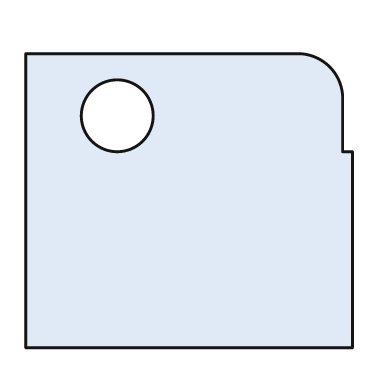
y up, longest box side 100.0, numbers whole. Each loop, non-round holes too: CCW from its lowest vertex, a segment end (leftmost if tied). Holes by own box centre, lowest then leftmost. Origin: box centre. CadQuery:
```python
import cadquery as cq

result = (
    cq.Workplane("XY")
    .moveTo(-50.0, -45.0)
    .lineTo(50.0, -45.0)
    .lineTo(50.0, 15.0)
    .lineTo(47.0, 15.0)
    .lineTo(47.0, 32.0)
    .threePointArc((43.0, 41.0), (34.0, 45.0))
    .lineTo(-50.0, 45.0)
    .close()
    .moveTo(-22.0, 26.0)
    .circle(11.0)
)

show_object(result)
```